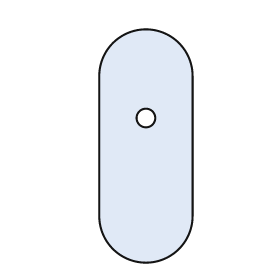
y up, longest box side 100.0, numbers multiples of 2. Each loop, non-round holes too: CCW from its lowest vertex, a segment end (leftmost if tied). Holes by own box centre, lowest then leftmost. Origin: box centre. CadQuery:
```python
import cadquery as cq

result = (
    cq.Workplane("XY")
    .moveTo(-20.0, -30.0)
    .threePointArc((0.0, -50.0), (20.0, -30.0))
    .lineTo(20.0, 30.0)
    .threePointArc((0.0, 50.0), (-20.0, 30.0))
    .close()
    .moveTo(0.0, 12.0)
    .circle(4.0)
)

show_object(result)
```